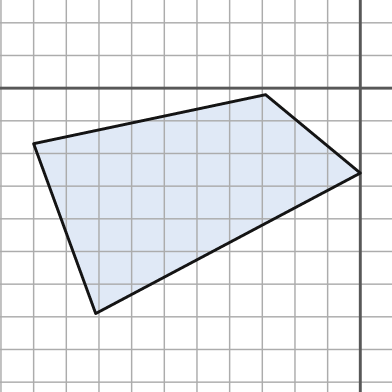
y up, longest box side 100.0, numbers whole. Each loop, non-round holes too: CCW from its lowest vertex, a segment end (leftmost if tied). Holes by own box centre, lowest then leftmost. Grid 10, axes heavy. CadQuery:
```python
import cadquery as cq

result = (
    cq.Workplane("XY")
    .moveTo(-81.0, -69.0)
    .lineTo(0.0, -26.0)
    .lineTo(-29.0, -2.0)
    .lineTo(-100.0, -17.0)
    .close()
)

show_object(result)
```